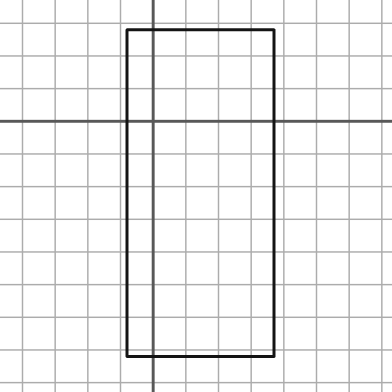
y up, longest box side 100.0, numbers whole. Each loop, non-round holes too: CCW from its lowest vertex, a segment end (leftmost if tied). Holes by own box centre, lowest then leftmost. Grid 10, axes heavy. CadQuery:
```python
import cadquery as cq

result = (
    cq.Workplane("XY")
    .moveTo(-8.0, -72.0)
    .lineTo(37.0, -72.0)
    .lineTo(37.0, 28.0)
    .lineTo(-8.0, 28.0)
    .close()
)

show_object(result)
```